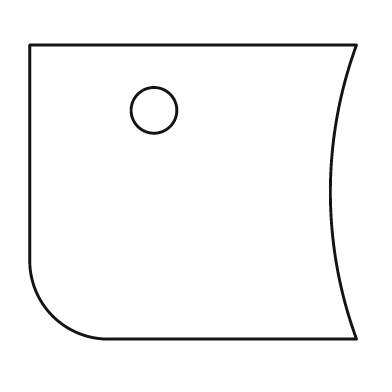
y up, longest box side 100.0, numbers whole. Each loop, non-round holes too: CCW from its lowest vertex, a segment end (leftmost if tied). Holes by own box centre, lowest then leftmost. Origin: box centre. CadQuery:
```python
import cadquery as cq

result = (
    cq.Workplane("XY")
    .moveTo(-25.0, -45.0)
    .lineTo(50.0, -45.0)
    .threePointArc((42.0, 0.0), (50.0, 45.0))
    .lineTo(-50.0, 45.0)
    .lineTo(-50.0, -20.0)
    .threePointArc((-43.0, -38.0), (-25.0, -45.0))
    .close()
    .moveTo(-12.0, 25.0)
    .circle(7.0)
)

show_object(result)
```